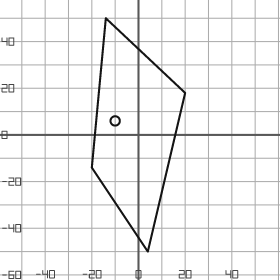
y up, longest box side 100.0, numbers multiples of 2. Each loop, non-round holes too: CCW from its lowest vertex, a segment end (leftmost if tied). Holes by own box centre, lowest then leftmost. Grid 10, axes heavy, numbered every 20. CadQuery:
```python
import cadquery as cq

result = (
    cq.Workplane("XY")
    .moveTo(4.0, -50.0)
    .lineTo(20.0, 18.0)
    .lineTo(-14.0, 50.0)
    .lineTo(-20.0, -14.0)
    .close()
    .moveTo(-10.0, 6.0)
    .circle(2.0)
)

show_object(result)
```